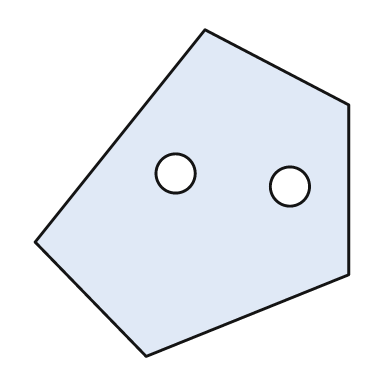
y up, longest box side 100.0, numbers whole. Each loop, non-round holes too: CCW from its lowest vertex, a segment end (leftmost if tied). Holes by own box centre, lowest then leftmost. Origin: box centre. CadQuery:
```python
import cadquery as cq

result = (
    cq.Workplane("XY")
    .moveTo(-14.0, -50.0)
    .lineTo(48.0, -25.0)
    .lineTo(48.0, 27.0)
    .lineTo(4.0, 50.0)
    .lineTo(-48.0, -15.0)
    .close()
    .moveTo(30.0, 2.0)
    .circle(6.0)
    .moveTo(-5.0, 6.0)
    .circle(6.0)
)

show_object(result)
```